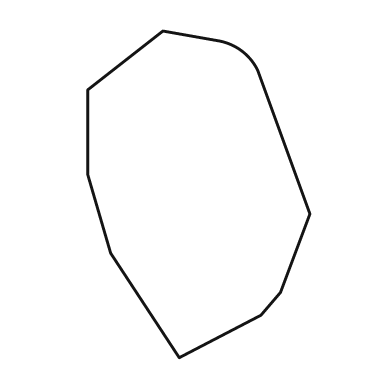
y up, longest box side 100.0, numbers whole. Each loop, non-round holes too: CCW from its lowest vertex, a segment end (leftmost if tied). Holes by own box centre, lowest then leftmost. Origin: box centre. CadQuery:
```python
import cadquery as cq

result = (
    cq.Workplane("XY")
    .moveTo(-6.0, -50.0)
    .lineTo(19.0, -37.0)
    .lineTo(25.0, -30.0)
    .lineTo(34.0, -6.0)
    .lineTo(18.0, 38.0)
    .threePointArc((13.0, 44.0), (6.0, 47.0))
    .lineTo(-11.0, 50.0)
    .lineTo(-34.0, 32.0)
    .lineTo(-34.0, 6.0)
    .lineTo(-27.0, -18.0)
    .close()
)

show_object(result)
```